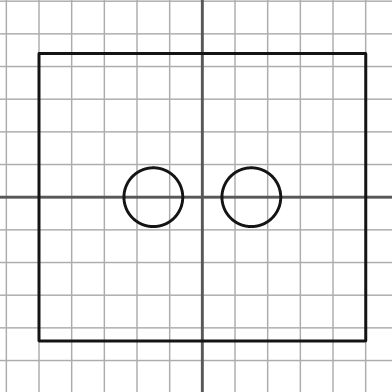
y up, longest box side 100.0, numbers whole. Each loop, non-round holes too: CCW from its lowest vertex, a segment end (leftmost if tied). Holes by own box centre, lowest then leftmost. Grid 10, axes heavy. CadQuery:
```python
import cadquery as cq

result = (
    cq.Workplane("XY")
    .moveTo(-50.0, -44.0)
    .lineTo(50.0, -44.0)
    .lineTo(50.0, 44.0)
    .lineTo(-50.0, 44.0)
    .close()
    .moveTo(-15.0, 0.0)
    .circle(9.0)
    .moveTo(15.0, 0.0)
    .circle(9.0)
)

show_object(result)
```